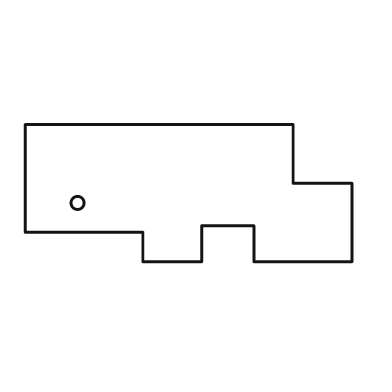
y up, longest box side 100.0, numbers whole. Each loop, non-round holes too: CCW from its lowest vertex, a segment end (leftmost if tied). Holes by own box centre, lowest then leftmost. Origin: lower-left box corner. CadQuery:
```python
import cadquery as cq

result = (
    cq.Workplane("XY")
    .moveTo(36.0, 0.0)
    .lineTo(54.0, 0.0)
    .lineTo(54.0, 11.0)
    .lineTo(70.0, 11.0)
    .lineTo(70.0, 0.0)
    .lineTo(100.0, 0.0)
    .lineTo(100.0, 24.0)
    .lineTo(82.0, 24.0)
    .lineTo(82.0, 42.0)
    .lineTo(0.0, 42.0)
    .lineTo(0.0, 9.0)
    .lineTo(36.0, 9.0)
    .close()
    .moveTo(16.0, 18.0)
    .circle(2.0)
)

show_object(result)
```